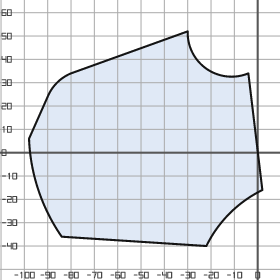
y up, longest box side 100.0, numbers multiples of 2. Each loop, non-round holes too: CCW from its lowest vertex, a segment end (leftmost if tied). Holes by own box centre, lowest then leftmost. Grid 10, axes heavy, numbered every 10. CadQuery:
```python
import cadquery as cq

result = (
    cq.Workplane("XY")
    .moveTo(-22.0, -40.0)
    .threePointArc((-12.0, -26.0), (2.0, -16.0))
    .lineTo(-4.0, 34.0)
    .threePointArc((-22.0, 36.0), (-30.0, 52.0))
    .lineTo(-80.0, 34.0)
    .threePointArc((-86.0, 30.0), (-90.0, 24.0))
    .lineTo(-98.0, 6.0)
    .threePointArc((-94.0, -16.0), (-84.0, -36.0))
    .close()
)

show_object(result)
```